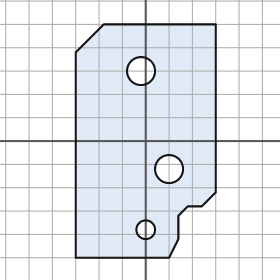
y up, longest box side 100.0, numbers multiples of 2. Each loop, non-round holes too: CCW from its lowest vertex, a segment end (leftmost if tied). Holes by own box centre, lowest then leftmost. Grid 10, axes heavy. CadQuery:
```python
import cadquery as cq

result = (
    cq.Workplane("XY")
    .moveTo(-30.0, -50.0)
    .lineTo(10.0, -50.0)
    .lineTo(14.0, -42.0)
    .lineTo(14.0, -32.0)
    .lineTo(18.0, -28.0)
    .lineTo(24.0, -28.0)
    .lineTo(30.0, -22.0)
    .lineTo(30.0, 50.0)
    .lineTo(-18.0, 50.0)
    .lineTo(-30.0, 38.0)
    .close()
    .moveTo(0.0, -38.0)
    .circle(4.0)
    .moveTo(10.0, -12.0)
    .circle(6.0)
    .moveTo(-2.0, 30.0)
    .circle(6.0)
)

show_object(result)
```